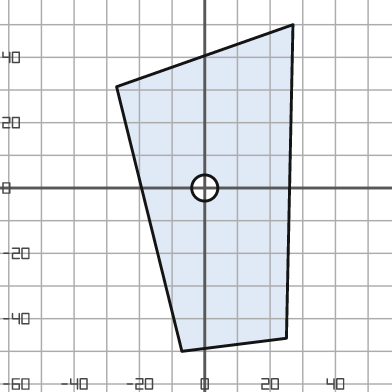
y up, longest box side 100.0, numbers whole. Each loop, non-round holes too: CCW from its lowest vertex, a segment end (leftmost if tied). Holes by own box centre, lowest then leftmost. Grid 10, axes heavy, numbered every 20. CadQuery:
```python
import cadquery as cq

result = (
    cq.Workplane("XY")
    .moveTo(-7.0, -50.0)
    .lineTo(25.0, -46.0)
    .lineTo(27.0, 50.0)
    .lineTo(-27.0, 31.0)
    .close()
    .moveTo(0.0, 0.0)
    .circle(4.0)
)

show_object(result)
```